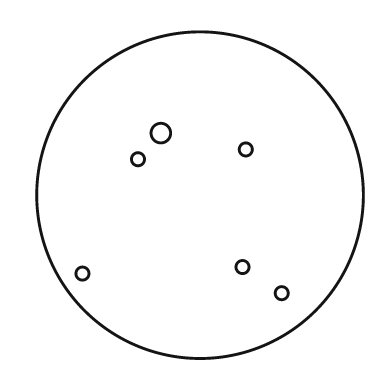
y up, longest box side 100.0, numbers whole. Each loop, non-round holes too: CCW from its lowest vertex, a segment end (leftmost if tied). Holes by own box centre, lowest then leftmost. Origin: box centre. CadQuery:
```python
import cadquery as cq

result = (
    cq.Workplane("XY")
    .moveTo(0.0, 0.0)
    .circle(50.0)
    .moveTo(25.0, -30.0)
    .circle(2.0)
    .moveTo(-36.0, -24.0)
    .circle(2.0)
    .moveTo(13.0, -22.0)
    .circle(2.0)
    .moveTo(-19.0, 11.0)
    .circle(2.0)
    .moveTo(14.0, 14.0)
    .circle(2.0)
    .moveTo(-12.0, 19.0)
    .circle(3.0)
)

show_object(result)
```